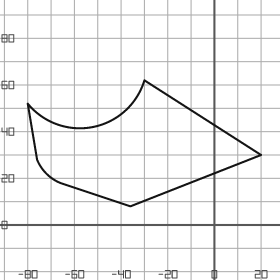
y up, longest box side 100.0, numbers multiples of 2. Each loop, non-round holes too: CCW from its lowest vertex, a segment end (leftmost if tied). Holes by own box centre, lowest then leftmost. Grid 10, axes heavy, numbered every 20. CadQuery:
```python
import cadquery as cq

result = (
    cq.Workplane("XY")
    .moveTo(-36.0, 8.0)
    .lineTo(20.0, 30.0)
    .lineTo(-30.0, 62.0)
    .threePointArc((-52.0, 42.0), (-80.0, 52.0))
    .lineTo(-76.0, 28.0)
    .threePointArc((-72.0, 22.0), (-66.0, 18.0))
    .close()
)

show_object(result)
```